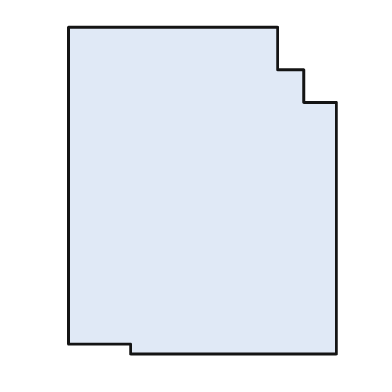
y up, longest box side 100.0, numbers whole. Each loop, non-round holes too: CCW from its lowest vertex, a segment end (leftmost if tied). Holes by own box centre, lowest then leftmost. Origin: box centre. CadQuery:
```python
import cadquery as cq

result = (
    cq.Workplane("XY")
    .moveTo(-22.0, -50.0)
    .lineTo(41.0, -50.0)
    .lineTo(41.0, 27.0)
    .lineTo(31.0, 27.0)
    .lineTo(31.0, 37.0)
    .lineTo(23.0, 37.0)
    .lineTo(23.0, 50.0)
    .lineTo(-41.0, 50.0)
    .lineTo(-41.0, -47.0)
    .lineTo(-22.0, -47.0)
    .close()
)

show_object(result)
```